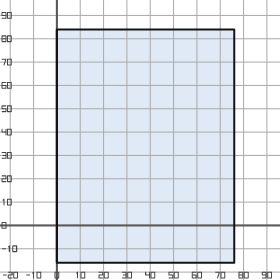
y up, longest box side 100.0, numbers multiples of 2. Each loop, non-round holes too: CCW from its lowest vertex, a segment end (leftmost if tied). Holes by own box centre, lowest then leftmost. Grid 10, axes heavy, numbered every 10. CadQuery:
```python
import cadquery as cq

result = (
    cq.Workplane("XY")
    .moveTo(0.0, -16.0)
    .lineTo(76.0, -16.0)
    .lineTo(76.0, 84.0)
    .lineTo(0.0, 84.0)
    .close()
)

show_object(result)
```